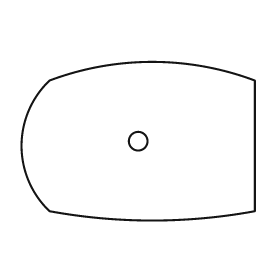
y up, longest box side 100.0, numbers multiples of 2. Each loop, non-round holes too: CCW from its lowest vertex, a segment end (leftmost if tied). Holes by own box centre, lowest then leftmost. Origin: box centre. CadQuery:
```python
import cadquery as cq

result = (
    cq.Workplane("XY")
    .moveTo(-38.0, -30.0)
    .threePointArc((6.0, -34.0), (50.0, -30.0))
    .lineTo(50.0, 26.0)
    .threePointArc((6.0, 34.0), (-38.0, 26.0))
    .threePointArc((-50.0, -2.0), (-38.0, -30.0))
    .close()
    .moveTo(0.0, 0.0)
    .circle(4.0)
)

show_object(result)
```